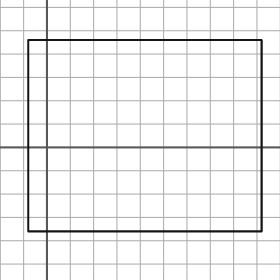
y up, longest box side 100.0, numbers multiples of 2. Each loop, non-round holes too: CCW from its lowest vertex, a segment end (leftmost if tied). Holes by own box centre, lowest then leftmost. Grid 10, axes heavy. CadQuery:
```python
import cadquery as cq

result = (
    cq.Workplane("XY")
    .moveTo(-8.0, -36.0)
    .lineTo(92.0, -36.0)
    .lineTo(92.0, 46.0)
    .lineTo(-8.0, 46.0)
    .close()
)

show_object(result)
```